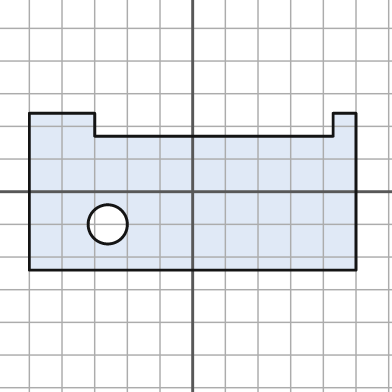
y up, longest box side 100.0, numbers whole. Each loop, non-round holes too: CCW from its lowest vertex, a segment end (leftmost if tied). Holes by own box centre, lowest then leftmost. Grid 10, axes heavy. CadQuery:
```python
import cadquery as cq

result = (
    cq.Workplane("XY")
    .moveTo(-50.0, -24.0)
    .lineTo(50.0, -24.0)
    .lineTo(50.0, 24.0)
    .lineTo(43.0, 24.0)
    .lineTo(43.0, 17.0)
    .lineTo(-30.0, 17.0)
    .lineTo(-30.0, 24.0)
    .lineTo(-50.0, 24.0)
    .close()
    .moveTo(-26.0, -10.0)
    .circle(6.0)
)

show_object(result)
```